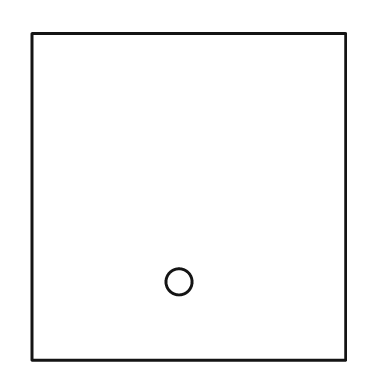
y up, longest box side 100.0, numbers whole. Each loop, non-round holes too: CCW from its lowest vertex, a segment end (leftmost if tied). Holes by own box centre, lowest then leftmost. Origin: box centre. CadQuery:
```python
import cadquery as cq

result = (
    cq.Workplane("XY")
    .moveTo(-48.0, -50.0)
    .lineTo(48.0, -50.0)
    .lineTo(48.0, 50.0)
    .lineTo(-48.0, 50.0)
    .close()
    .moveTo(-3.0, -26.0)
    .circle(4.0)
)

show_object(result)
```